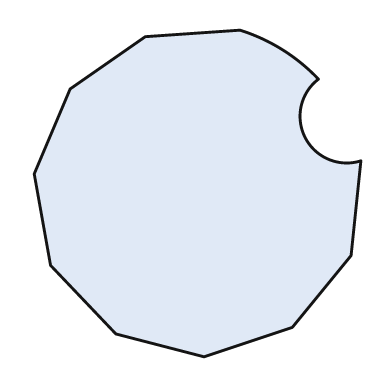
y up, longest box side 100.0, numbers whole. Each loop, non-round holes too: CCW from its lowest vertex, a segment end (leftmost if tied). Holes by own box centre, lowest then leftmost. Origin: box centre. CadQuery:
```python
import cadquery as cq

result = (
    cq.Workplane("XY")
    .moveTo(2.0, -50.0)
    .lineTo(29.0, -41.0)
    .lineTo(47.0, -19.0)
    .lineTo(50.0, 10.0)
    .threePointArc((33.0, 17.0), (37.0, 35.0))
    .threePointArc((26.0, 44.0), (13.0, 50.0))
    .lineTo(-16.0, 48.0)
    .lineTo(-39.0, 32.0)
    .lineTo(-50.0, 6.0)
    .lineTo(-45.0, -22.0)
    .lineTo(-25.0, -43.0)
    .close()
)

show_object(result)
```